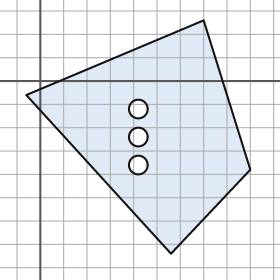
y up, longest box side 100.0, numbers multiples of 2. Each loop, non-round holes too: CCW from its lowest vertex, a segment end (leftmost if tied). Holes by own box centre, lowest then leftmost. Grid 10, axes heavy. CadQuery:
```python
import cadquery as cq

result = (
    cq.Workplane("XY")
    .moveTo(56.0, -74.0)
    .lineTo(90.0, -38.0)
    .lineTo(70.0, 26.0)
    .lineTo(-6.0, -6.0)
    .close()
    .moveTo(42.0, -36.0)
    .circle(4.0)
    .moveTo(42.0, -24.0)
    .circle(4.0)
    .moveTo(42.0, -12.0)
    .circle(4.0)
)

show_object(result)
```